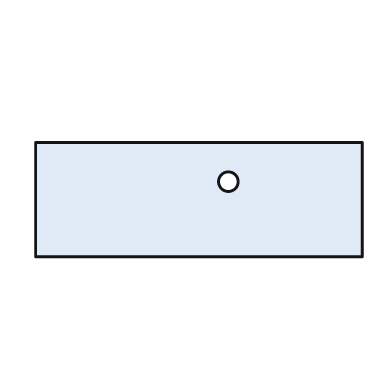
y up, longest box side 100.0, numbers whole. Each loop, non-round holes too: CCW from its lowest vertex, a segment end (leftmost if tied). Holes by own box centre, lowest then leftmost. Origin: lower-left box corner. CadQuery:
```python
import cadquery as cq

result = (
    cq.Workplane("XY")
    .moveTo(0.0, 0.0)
    .lineTo(100.0, 0.0)
    .lineTo(100.0, 35.0)
    .lineTo(0.0, 35.0)
    .close()
    .moveTo(59.0, 23.0)
    .circle(3.0)
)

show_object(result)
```